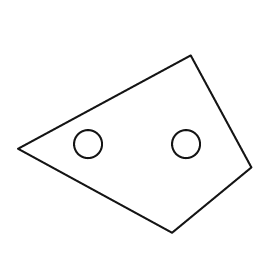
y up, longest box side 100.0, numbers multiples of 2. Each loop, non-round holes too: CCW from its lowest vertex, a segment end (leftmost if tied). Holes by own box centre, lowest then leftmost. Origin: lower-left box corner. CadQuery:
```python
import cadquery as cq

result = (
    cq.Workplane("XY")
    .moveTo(66.0, 0.0)
    .lineTo(100.0, 28.0)
    .lineTo(74.0, 76.0)
    .lineTo(0.0, 36.0)
    .close()
    .moveTo(30.0, 38.0)
    .circle(6.0)
    .moveTo(72.0, 38.0)
    .circle(6.0)
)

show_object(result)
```